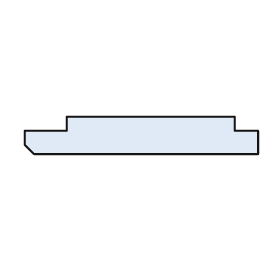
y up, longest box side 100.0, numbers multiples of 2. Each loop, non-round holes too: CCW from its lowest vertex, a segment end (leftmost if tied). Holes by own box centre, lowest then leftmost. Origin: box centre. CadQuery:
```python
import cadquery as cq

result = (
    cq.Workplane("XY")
    .moveTo(-46.0, -8.0)
    .lineTo(50.0, -8.0)
    .lineTo(50.0, 2.0)
    .lineTo(40.0, 2.0)
    .lineTo(40.0, 8.0)
    .lineTo(-32.0, 8.0)
    .lineTo(-32.0, 2.0)
    .lineTo(-50.0, 2.0)
    .lineTo(-50.0, -4.0)
    .close()
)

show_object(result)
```